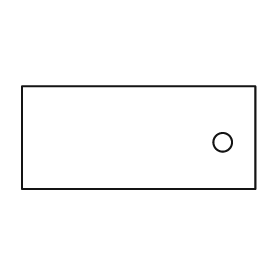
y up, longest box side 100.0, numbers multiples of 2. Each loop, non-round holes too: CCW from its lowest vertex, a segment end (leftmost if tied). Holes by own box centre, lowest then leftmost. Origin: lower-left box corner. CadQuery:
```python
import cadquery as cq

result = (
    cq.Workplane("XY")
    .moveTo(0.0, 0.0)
    .lineTo(100.0, 0.0)
    .lineTo(100.0, 44.0)
    .lineTo(0.0, 44.0)
    .close()
    .moveTo(86.0, 20.0)
    .circle(4.0)
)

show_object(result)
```